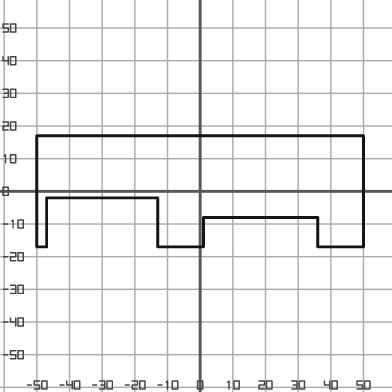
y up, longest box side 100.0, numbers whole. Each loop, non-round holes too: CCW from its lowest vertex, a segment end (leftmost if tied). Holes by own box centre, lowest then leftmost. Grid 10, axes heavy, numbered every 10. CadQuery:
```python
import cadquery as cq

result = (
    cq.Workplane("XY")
    .moveTo(-50.0, -17.0)
    .lineTo(-47.0, -17.0)
    .lineTo(-47.0, -2.0)
    .lineTo(-13.0, -2.0)
    .lineTo(-13.0, -17.0)
    .lineTo(1.0, -17.0)
    .lineTo(1.0, -8.0)
    .lineTo(36.0, -8.0)
    .lineTo(36.0, -17.0)
    .lineTo(50.0, -17.0)
    .lineTo(50.0, 17.0)
    .lineTo(-50.0, 17.0)
    .close()
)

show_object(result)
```